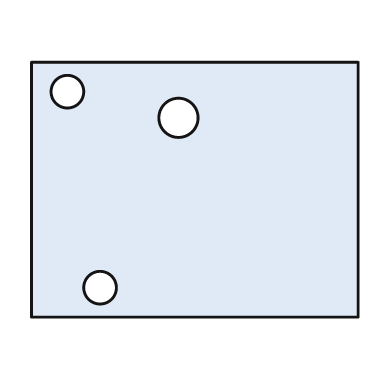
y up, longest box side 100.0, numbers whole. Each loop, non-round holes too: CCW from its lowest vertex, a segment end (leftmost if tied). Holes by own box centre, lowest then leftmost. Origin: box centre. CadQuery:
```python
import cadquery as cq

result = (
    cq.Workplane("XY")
    .moveTo(-50.0, -39.0)
    .lineTo(50.0, -39.0)
    .lineTo(50.0, 39.0)
    .lineTo(-50.0, 39.0)
    .close()
    .moveTo(-29.0, -30.0)
    .circle(5.0)
    .moveTo(-5.0, 22.0)
    .circle(6.0)
    .moveTo(-39.0, 30.0)
    .circle(5.0)
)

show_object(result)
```